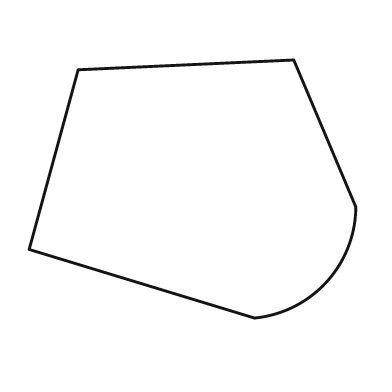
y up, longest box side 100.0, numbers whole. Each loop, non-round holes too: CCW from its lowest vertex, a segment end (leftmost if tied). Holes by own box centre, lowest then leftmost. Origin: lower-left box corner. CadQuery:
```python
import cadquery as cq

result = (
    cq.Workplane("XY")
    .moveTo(69.0, 0.0)
    .threePointArc((91.0, 11.0), (100.0, 34.0))
    .lineTo(81.0, 79.0)
    .lineTo(15.0, 76.0)
    .lineTo(0.0, 21.0)
    .close()
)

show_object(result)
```